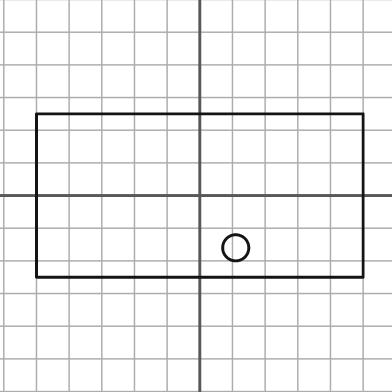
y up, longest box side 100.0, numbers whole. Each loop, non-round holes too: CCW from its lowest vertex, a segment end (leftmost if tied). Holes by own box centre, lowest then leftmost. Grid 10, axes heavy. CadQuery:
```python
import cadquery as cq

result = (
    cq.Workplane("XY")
    .moveTo(-50.0, -25.0)
    .lineTo(50.0, -25.0)
    .lineTo(50.0, 25.0)
    .lineTo(-50.0, 25.0)
    .close()
    .moveTo(11.0, -16.0)
    .circle(4.0)
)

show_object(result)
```